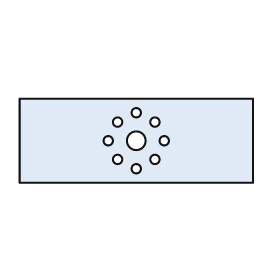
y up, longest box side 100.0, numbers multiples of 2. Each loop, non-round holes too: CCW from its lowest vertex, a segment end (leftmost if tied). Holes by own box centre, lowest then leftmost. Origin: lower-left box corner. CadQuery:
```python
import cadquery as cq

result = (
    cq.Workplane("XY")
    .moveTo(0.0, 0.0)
    .lineTo(100.0, 0.0)
    .lineTo(100.0, 36.0)
    .lineTo(0.0, 36.0)
    .close()
    .moveTo(50.0, 6.0)
    .circle(2.0)
    .moveTo(42.0, 10.0)
    .circle(2.0)
    .moveTo(58.0, 10.0)
    .circle(2.0)
    .moveTo(38.0, 18.0)
    .circle(2.0)
    .moveTo(50.0, 18.0)
    .circle(4.0)
    .moveTo(62.0, 18.0)
    .circle(2.0)
    .moveTo(42.0, 26.0)
    .circle(2.0)
    .moveTo(58.0, 26.0)
    .circle(2.0)
    .moveTo(50.0, 30.0)
    .circle(2.0)
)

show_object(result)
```